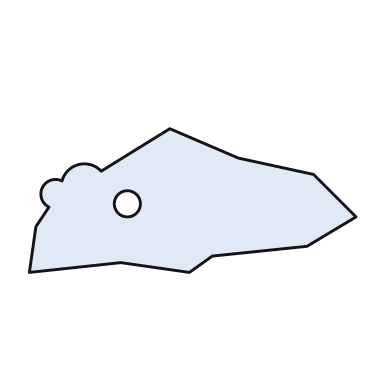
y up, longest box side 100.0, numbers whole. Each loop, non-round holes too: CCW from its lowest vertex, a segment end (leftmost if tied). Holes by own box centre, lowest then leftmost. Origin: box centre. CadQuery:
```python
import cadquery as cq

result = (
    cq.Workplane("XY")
    .moveTo(-50.0, -22.0)
    .lineTo(-22.0, -19.0)
    .lineTo(-1.0, -22.0)
    .lineTo(6.0, -17.0)
    .lineTo(35.0, -14.0)
    .lineTo(50.0, -5.0)
    .lineTo(37.0, 8.0)
    .lineTo(14.0, 13.0)
    .lineTo(-7.0, 22.0)
    .lineTo(-28.0, 9.0)
    .threePointArc((-35.0, 11.0), (-40.0, 6.0))
    .threePointArc((-46.0, 4.0), (-44.0, -2.0))
    .lineTo(-48.0, -8.0)
    .close()
    .moveTo(-20.0, -1.0)
    .circle(4.0)
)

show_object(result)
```